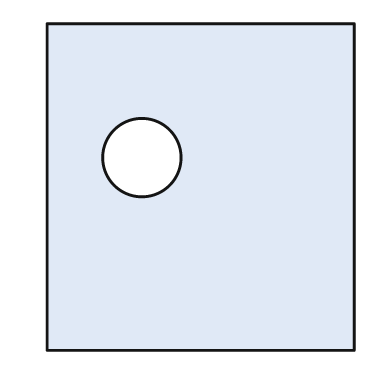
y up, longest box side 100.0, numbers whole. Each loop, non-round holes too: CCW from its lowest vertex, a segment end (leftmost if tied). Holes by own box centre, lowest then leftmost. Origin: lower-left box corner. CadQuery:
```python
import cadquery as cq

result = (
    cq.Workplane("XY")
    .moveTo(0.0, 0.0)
    .lineTo(94.0, 0.0)
    .lineTo(94.0, 100.0)
    .lineTo(0.0, 100.0)
    .close()
    .moveTo(29.0, 59.0)
    .circle(12.0)
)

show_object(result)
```